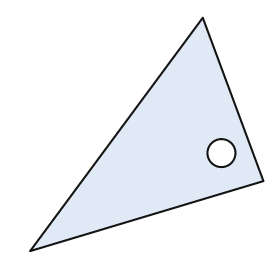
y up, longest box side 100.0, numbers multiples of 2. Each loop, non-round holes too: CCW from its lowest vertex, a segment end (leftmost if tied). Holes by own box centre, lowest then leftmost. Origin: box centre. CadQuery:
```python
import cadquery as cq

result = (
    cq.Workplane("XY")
    .moveTo(-50.0, -50.0)
    .lineTo(50.0, -20.0)
    .lineTo(24.0, 50.0)
    .close()
    .moveTo(32.0, -8.0)
    .circle(6.0)
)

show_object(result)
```